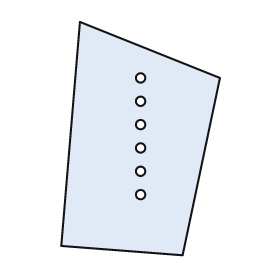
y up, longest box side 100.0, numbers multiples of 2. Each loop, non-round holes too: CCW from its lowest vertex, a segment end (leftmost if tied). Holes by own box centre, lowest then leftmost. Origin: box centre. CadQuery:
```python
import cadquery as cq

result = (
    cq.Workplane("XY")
    .moveTo(18.0, -50.0)
    .lineTo(34.0, 26.0)
    .lineTo(-26.0, 50.0)
    .lineTo(-34.0, -46.0)
    .close()
    .moveTo(0.0, -24.0)
    .circle(2.0)
    .moveTo(0.0, -14.0)
    .circle(2.0)
    .moveTo(0.0, -4.0)
    .circle(2.0)
    .moveTo(0.0, 6.0)
    .circle(2.0)
    .moveTo(0.0, 16.0)
    .circle(2.0)
    .moveTo(0.0, 26.0)
    .circle(2.0)
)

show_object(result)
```